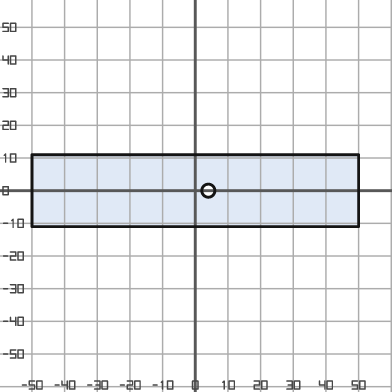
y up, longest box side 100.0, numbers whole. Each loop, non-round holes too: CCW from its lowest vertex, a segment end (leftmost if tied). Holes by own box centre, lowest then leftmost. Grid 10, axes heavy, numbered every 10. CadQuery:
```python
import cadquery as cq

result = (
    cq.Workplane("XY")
    .moveTo(-50.0, -11.0)
    .lineTo(50.0, -11.0)
    .lineTo(50.0, 11.0)
    .lineTo(-50.0, 11.0)
    .close()
    .moveTo(4.0, 0.0)
    .circle(2.0)
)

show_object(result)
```